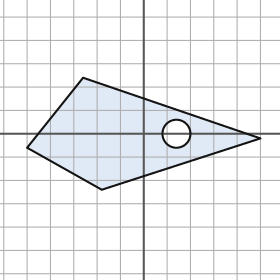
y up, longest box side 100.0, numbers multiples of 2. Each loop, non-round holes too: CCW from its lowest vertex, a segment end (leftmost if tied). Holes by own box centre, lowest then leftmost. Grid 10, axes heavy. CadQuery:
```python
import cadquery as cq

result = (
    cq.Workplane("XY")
    .moveTo(-18.0, -24.0)
    .lineTo(50.0, -2.0)
    .lineTo(-26.0, 24.0)
    .lineTo(-50.0, -6.0)
    .close()
    .moveTo(14.0, 0.0)
    .circle(6.0)
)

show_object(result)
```